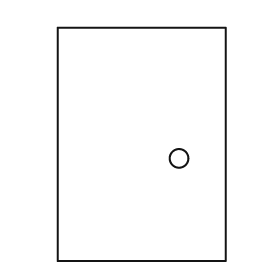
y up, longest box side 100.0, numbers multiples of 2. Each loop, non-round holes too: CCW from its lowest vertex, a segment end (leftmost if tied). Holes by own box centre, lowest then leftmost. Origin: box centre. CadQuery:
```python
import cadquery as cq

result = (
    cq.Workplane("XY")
    .moveTo(-36.0, -50.0)
    .lineTo(36.0, -50.0)
    .lineTo(36.0, 50.0)
    .lineTo(-36.0, 50.0)
    .close()
    .moveTo(16.0, -6.0)
    .circle(4.0)
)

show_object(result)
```